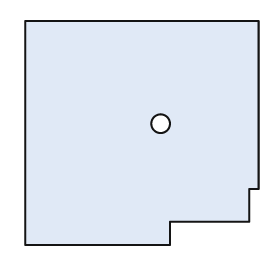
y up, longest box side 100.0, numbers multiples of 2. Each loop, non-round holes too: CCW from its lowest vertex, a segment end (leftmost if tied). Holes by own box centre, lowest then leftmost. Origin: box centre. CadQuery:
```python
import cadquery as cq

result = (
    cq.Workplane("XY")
    .moveTo(-50.0, -48.0)
    .lineTo(12.0, -48.0)
    .lineTo(12.0, -38.0)
    .lineTo(46.0, -38.0)
    .lineTo(46.0, -24.0)
    .lineTo(50.0, -24.0)
    .lineTo(50.0, 48.0)
    .lineTo(-50.0, 48.0)
    .close()
    .moveTo(8.0, 4.0)
    .circle(4.0)
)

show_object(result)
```